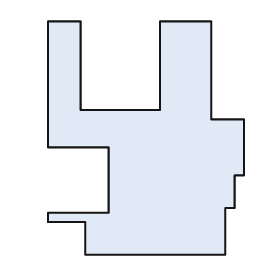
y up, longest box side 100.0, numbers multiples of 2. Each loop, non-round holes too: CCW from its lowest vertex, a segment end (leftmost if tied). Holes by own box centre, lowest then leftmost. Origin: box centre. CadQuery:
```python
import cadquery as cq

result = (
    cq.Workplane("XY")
    .moveTo(-26.0, -50.0)
    .lineTo(34.0, -50.0)
    .lineTo(34.0, -30.0)
    .lineTo(38.0, -30.0)
    .lineTo(38.0, -16.0)
    .lineTo(42.0, -16.0)
    .lineTo(42.0, 8.0)
    .lineTo(28.0, 8.0)
    .lineTo(28.0, 50.0)
    .lineTo(6.0, 50.0)
    .lineTo(6.0, 12.0)
    .lineTo(-28.0, 12.0)
    .lineTo(-28.0, 50.0)
    .lineTo(-42.0, 50.0)
    .lineTo(-42.0, -4.0)
    .lineTo(-16.0, -4.0)
    .lineTo(-16.0, -32.0)
    .lineTo(-42.0, -32.0)
    .lineTo(-42.0, -36.0)
    .lineTo(-26.0, -36.0)
    .close()
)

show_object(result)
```